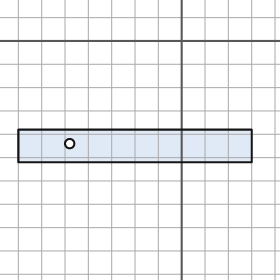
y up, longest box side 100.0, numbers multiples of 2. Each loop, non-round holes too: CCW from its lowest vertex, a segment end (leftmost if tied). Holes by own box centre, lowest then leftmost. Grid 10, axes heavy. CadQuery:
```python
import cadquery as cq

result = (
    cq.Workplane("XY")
    .moveTo(-70.0, -52.0)
    .lineTo(30.0, -52.0)
    .lineTo(30.0, -38.0)
    .lineTo(-70.0, -38.0)
    .close()
    .moveTo(-48.0, -44.0)
    .circle(2.0)
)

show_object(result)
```